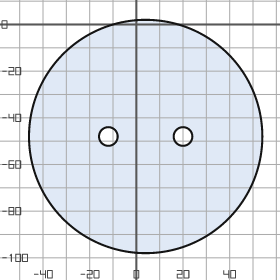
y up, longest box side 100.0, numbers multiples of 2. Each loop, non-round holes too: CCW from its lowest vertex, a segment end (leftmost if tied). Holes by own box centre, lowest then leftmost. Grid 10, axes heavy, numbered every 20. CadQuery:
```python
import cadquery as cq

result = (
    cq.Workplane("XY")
    .moveTo(4.0, -48.0)
    .circle(50.0)
    .moveTo(-12.0, -48.0)
    .circle(4.0)
    .moveTo(20.0, -48.0)
    .circle(4.0)
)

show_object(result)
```